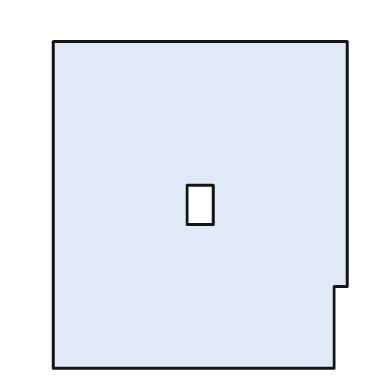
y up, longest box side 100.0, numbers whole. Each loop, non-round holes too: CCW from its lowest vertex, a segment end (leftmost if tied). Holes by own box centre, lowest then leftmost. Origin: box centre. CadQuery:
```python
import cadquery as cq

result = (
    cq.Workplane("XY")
    .moveTo(-45.0, -50.0)
    .lineTo(41.0, -50.0)
    .lineTo(41.0, -25.0)
    .lineTo(45.0, -25.0)
    .lineTo(45.0, 50.0)
    .lineTo(-45.0, 50.0)
    .close()
    .moveTo(-4.0, -6.0)
    .lineTo(4.0, -6.0)
    .lineTo(4.0, 6.0)
    .lineTo(-4.0, 6.0)
    .close()
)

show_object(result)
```